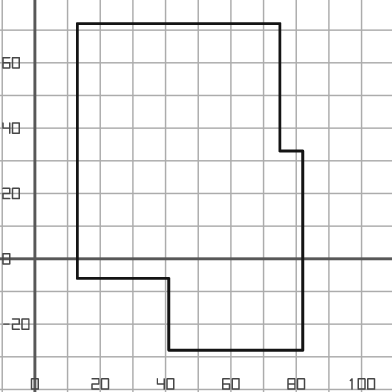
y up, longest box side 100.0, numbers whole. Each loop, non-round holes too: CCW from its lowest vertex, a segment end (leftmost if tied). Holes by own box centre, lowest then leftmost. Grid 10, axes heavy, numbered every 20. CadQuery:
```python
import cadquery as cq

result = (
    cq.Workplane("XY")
    .moveTo(41.0, -28.0)
    .lineTo(82.0, -28.0)
    .lineTo(82.0, 33.0)
    .lineTo(75.0, 33.0)
    .lineTo(75.0, 72.0)
    .lineTo(13.0, 72.0)
    .lineTo(13.0, -6.0)
    .lineTo(41.0, -6.0)
    .close()
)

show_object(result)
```